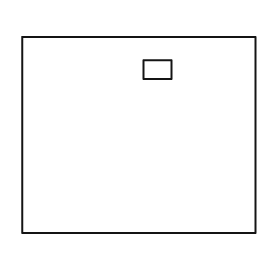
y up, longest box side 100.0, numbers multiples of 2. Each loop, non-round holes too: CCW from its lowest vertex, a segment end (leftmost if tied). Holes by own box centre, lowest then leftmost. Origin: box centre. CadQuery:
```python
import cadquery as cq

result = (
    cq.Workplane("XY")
    .moveTo(-50.0, -42.0)
    .lineTo(50.0, -42.0)
    .lineTo(50.0, 42.0)
    .lineTo(-50.0, 42.0)
    .close()
    .moveTo(2.0, 24.0)
    .lineTo(14.0, 24.0)
    .lineTo(14.0, 32.0)
    .lineTo(2.0, 32.0)
    .close()
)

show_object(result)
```